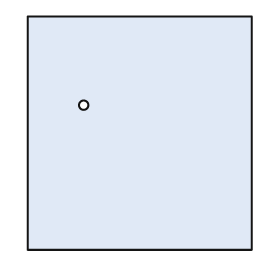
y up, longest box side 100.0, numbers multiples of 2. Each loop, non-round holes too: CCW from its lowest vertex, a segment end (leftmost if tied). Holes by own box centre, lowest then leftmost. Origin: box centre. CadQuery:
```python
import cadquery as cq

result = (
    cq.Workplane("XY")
    .moveTo(-48.0, -50.0)
    .lineTo(48.0, -50.0)
    .lineTo(48.0, 50.0)
    .lineTo(-48.0, 50.0)
    .close()
    .moveTo(-24.0, 12.0)
    .circle(2.0)
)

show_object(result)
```